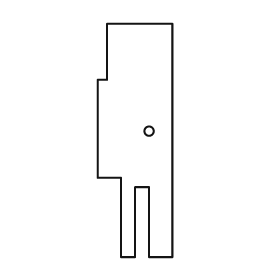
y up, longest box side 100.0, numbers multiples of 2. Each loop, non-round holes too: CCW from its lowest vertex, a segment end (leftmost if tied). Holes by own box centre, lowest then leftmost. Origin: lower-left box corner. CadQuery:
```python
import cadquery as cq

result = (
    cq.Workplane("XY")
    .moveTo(10.0, 0.0)
    .lineTo(16.0, 0.0)
    .lineTo(16.0, 30.0)
    .lineTo(22.0, 30.0)
    .lineTo(22.0, 0.0)
    .lineTo(32.0, 0.0)
    .lineTo(32.0, 100.0)
    .lineTo(4.0, 100.0)
    .lineTo(4.0, 76.0)
    .lineTo(0.0, 76.0)
    .lineTo(0.0, 34.0)
    .lineTo(10.0, 34.0)
    .close()
    .moveTo(22.0, 54.0)
    .circle(2.0)
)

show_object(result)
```